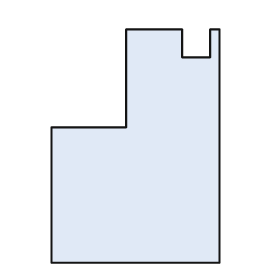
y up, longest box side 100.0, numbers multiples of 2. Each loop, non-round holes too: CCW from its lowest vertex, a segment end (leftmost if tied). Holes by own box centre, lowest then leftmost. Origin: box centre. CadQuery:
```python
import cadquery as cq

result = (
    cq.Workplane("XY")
    .moveTo(-36.0, -50.0)
    .lineTo(36.0, -50.0)
    .lineTo(36.0, 50.0)
    .lineTo(32.0, 50.0)
    .lineTo(32.0, 38.0)
    .lineTo(20.0, 38.0)
    .lineTo(20.0, 50.0)
    .lineTo(-4.0, 50.0)
    .lineTo(-4.0, 8.0)
    .lineTo(-36.0, 8.0)
    .close()
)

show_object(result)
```